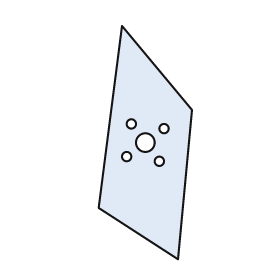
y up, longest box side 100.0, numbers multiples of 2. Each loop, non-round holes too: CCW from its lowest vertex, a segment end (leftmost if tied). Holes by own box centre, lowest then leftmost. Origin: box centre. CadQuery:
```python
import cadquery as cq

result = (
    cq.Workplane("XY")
    .moveTo(14.0, -50.0)
    .lineTo(20.0, 14.0)
    .lineTo(-10.0, 50.0)
    .lineTo(-20.0, -28.0)
    .close()
    .moveTo(6.0, -8.0)
    .circle(2.0)
    .moveTo(-8.0, -6.0)
    .circle(2.0)
    .moveTo(0.0, 0.0)
    .circle(4.0)
    .moveTo(8.0, 6.0)
    .circle(2.0)
    .moveTo(-6.0, 8.0)
    .circle(2.0)
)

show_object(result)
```